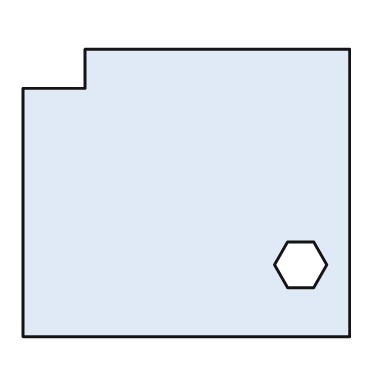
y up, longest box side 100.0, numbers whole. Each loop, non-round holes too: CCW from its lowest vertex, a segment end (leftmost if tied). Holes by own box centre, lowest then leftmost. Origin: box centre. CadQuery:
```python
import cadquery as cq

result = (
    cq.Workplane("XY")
    .moveTo(-50.0, -44.0)
    .lineTo(50.0, -44.0)
    .lineTo(50.0, 44.0)
    .lineTo(-31.0, 44.0)
    .lineTo(-31.0, 32.0)
    .lineTo(-50.0, 32.0)
    .close()
    .moveTo(31.0, -29.0)
    .lineTo(39.0, -29.0)
    .lineTo(43.0, -22.0)
    .lineTo(39.0, -15.0)
    .lineTo(31.0, -15.0)
    .lineTo(27.0, -22.0)
    .close()
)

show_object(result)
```